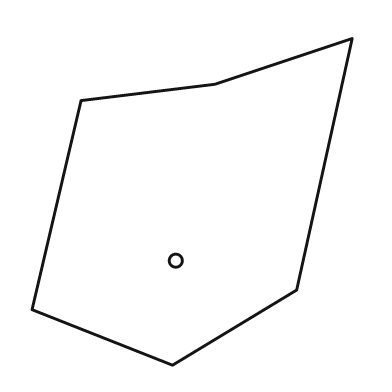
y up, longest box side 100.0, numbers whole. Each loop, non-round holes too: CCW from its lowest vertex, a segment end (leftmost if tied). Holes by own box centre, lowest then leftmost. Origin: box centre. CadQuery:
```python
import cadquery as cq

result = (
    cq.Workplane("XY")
    .moveTo(-6.0, -50.0)
    .lineTo(32.0, -27.0)
    .lineTo(49.0, 50.0)
    .lineTo(7.0, 36.0)
    .lineTo(-34.0, 31.0)
    .lineTo(-49.0, -33.0)
    .close()
    .moveTo(-5.0, -18.0)
    .circle(2.0)
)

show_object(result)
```